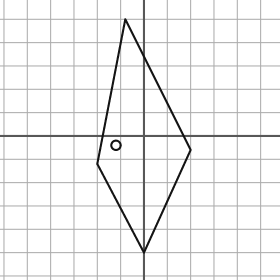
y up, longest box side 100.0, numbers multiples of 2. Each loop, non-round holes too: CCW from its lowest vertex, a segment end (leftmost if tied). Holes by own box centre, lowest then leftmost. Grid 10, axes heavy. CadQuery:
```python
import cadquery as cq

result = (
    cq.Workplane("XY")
    .moveTo(0.0, -50.0)
    .lineTo(20.0, -6.0)
    .lineTo(-8.0, 50.0)
    .lineTo(-20.0, -12.0)
    .close()
    .moveTo(-12.0, -4.0)
    .circle(2.0)
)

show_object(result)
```